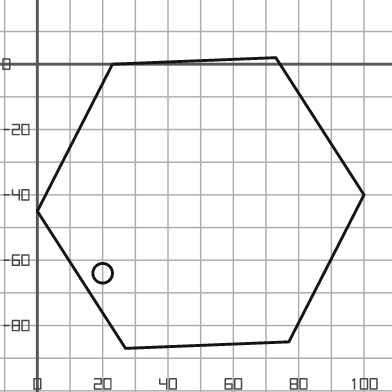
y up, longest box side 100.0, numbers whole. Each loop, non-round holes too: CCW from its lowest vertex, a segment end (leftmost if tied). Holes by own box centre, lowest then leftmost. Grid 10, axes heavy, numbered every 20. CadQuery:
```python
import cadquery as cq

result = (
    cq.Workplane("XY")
    .moveTo(27.0, -87.0)
    .lineTo(77.0, -85.0)
    .lineTo(100.0, -40.0)
    .lineTo(73.0, 2.0)
    .lineTo(23.0, 0.0)
    .lineTo(0.0, -45.0)
    .close()
    .moveTo(20.0, -64.0)
    .circle(3.0)
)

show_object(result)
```